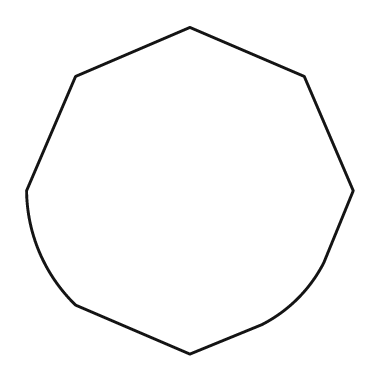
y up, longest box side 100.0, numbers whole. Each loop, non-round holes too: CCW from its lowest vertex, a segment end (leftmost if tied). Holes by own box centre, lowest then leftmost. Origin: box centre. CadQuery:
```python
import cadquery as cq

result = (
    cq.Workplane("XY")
    .moveTo(0.0, -50.0)
    .lineTo(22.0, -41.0)
    .threePointArc((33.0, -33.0), (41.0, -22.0))
    .lineTo(50.0, 0.0)
    .lineTo(35.0, 35.0)
    .lineTo(0.0, 50.0)
    .lineTo(-35.0, 35.0)
    .lineTo(-50.0, 0.0)
    .threePointArc((-46.0, -19.0), (-35.0, -35.0))
    .close()
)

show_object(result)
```